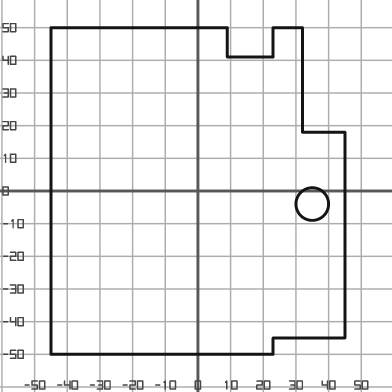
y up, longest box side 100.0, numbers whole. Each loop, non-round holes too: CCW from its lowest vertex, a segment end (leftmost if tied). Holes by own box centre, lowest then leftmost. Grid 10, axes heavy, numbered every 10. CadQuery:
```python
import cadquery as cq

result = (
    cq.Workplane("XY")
    .moveTo(-45.0, -50.0)
    .lineTo(23.0, -50.0)
    .lineTo(23.0, -45.0)
    .lineTo(45.0, -45.0)
    .lineTo(45.0, 18.0)
    .lineTo(32.0, 18.0)
    .lineTo(32.0, 50.0)
    .lineTo(23.0, 50.0)
    .lineTo(23.0, 41.0)
    .lineTo(9.0, 41.0)
    .lineTo(9.0, 50.0)
    .lineTo(-45.0, 50.0)
    .close()
    .moveTo(35.0, -4.0)
    .circle(5.0)
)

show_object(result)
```